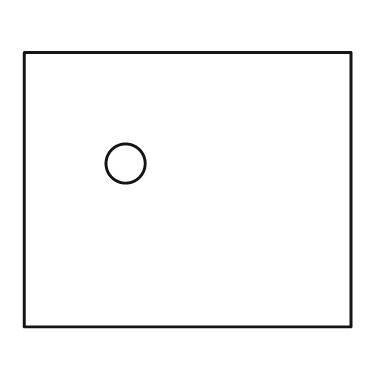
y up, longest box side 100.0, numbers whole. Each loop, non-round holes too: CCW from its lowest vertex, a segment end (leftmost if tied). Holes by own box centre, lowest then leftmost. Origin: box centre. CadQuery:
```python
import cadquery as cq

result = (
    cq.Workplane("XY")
    .moveTo(-50.0, -42.0)
    .lineTo(50.0, -42.0)
    .lineTo(50.0, 42.0)
    .lineTo(-50.0, 42.0)
    .close()
    .moveTo(-19.0, 8.0)
    .circle(6.0)
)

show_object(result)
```